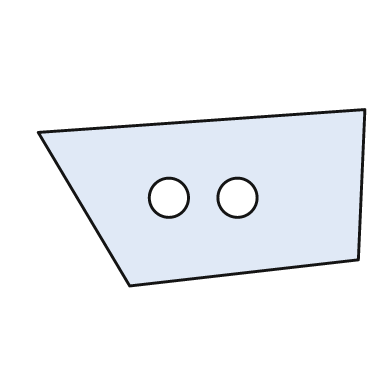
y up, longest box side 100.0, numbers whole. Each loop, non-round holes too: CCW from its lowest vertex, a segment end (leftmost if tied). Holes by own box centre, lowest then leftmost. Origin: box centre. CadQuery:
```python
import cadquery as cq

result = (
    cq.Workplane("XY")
    .moveTo(-22.0, -27.0)
    .lineTo(48.0, -19.0)
    .lineTo(50.0, 27.0)
    .lineTo(-50.0, 20.0)
    .close()
    .moveTo(-10.0, 0.0)
    .circle(6.0)
    .moveTo(11.0, 0.0)
    .circle(6.0)
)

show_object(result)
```